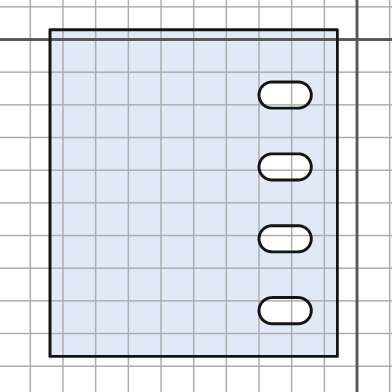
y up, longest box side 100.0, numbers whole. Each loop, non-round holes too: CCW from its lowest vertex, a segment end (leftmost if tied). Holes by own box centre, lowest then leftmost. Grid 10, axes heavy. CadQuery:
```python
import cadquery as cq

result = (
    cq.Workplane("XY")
    .moveTo(-94.0, -97.0)
    .lineTo(-6.0, -97.0)
    .lineTo(-6.0, 3.0)
    .lineTo(-94.0, 3.0)
    .close()
    .moveTo(-26.0, -87.0)
    .lineTo(-18.0, -87.0)
    .threePointArc((-14.0, -83.0), (-18.0, -79.0))
    .lineTo(-26.0, -79.0)
    .threePointArc((-30.0, -83.0), (-26.0, -87.0))
    .close()
    .moveTo(-26.0, -65.0)
    .lineTo(-18.0, -65.0)
    .threePointArc((-14.0, -61.0), (-18.0, -57.0))
    .lineTo(-26.0, -57.0)
    .threePointArc((-30.0, -61.0), (-26.0, -65.0))
    .close()
    .moveTo(-26.0, -43.0)
    .lineTo(-18.0, -43.0)
    .threePointArc((-14.0, -39.0), (-18.0, -35.0))
    .lineTo(-26.0, -35.0)
    .threePointArc((-30.0, -39.0), (-26.0, -43.0))
    .close()
    .moveTo(-26.0, -21.0)
    .lineTo(-18.0, -21.0)
    .threePointArc((-14.0, -17.0), (-18.0, -13.0))
    .lineTo(-26.0, -13.0)
    .threePointArc((-30.0, -17.0), (-26.0, -21.0))
    .close()
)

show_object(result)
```